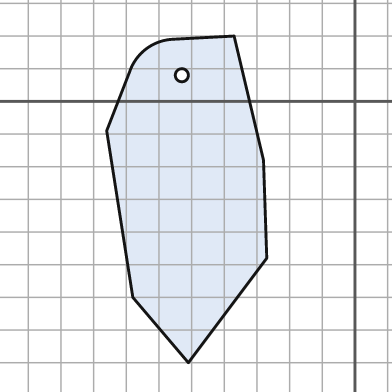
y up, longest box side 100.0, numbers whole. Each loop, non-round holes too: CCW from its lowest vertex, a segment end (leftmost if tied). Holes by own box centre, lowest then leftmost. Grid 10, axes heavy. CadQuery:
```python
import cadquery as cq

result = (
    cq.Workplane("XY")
    .moveTo(-51.0, -80.0)
    .lineTo(-27.0, -48.0)
    .lineTo(-28.0, -18.0)
    .lineTo(-37.0, 20.0)
    .lineTo(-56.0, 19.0)
    .threePointArc((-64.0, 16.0), (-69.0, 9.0))
    .lineTo(-76.0, -9.0)
    .lineTo(-68.0, -60.0)
    .close()
    .moveTo(-53.0, 8.0)
    .circle(2.0)
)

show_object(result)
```